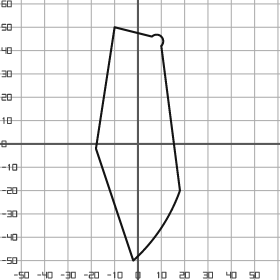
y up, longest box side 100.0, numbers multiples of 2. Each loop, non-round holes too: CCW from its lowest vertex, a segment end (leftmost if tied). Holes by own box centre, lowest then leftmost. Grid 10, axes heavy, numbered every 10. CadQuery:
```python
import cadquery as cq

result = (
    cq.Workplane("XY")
    .moveTo(-2.0, -50.0)
    .threePointArc((10.0, -36.0), (18.0, -20.0))
    .lineTo(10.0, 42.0)
    .threePointArc((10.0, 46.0), (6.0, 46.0))
    .lineTo(-10.0, 50.0)
    .lineTo(-18.0, -2.0)
    .close()
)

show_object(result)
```